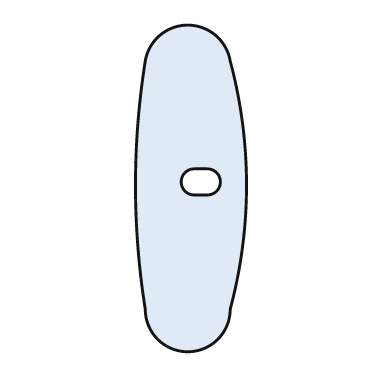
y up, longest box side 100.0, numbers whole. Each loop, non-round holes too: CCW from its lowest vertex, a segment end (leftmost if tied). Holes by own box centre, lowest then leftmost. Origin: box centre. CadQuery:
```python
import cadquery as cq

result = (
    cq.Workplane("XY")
    .moveTo(-14.0, -37.0)
    .threePointArc((-1.0, -50.0), (12.0, -37.0))
    .threePointArc((17.0, 1.0), (12.0, 39.0))
    .threePointArc((-1.0, 50.0), (-14.0, 39.0))
    .threePointArc((-17.0, 1.0), (-14.0, -37.0))
    .close()
    .moveTo(1.0, -2.0)
    .lineTo(5.0, -2.0)
    .threePointArc((9.0, 2.0), (5.0, 6.0))
    .lineTo(1.0, 6.0)
    .threePointArc((-3.0, 2.0), (1.0, -2.0))
    .close()
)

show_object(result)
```